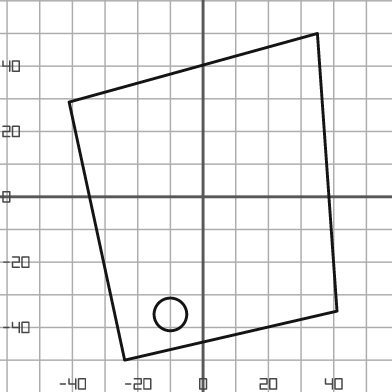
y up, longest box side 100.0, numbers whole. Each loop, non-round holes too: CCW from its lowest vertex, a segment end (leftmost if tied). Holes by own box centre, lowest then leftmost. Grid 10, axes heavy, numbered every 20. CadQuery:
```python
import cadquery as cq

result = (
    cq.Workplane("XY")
    .moveTo(-24.0, -50.0)
    .lineTo(41.0, -35.0)
    .lineTo(35.0, 50.0)
    .lineTo(-41.0, 29.0)
    .close()
    .moveTo(-10.0, -36.0)
    .circle(5.0)
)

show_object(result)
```